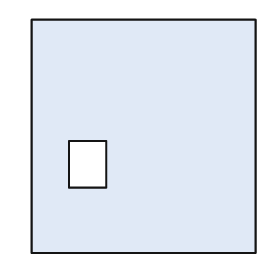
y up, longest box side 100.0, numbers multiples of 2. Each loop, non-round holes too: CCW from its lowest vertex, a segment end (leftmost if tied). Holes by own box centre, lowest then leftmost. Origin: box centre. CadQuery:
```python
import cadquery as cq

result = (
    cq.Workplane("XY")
    .moveTo(-48.0, -50.0)
    .lineTo(48.0, -50.0)
    .lineTo(48.0, 50.0)
    .lineTo(-48.0, 50.0)
    .close()
    .moveTo(-32.0, -22.0)
    .lineTo(-16.0, -22.0)
    .lineTo(-16.0, -2.0)
    .lineTo(-32.0, -2.0)
    .close()
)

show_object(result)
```